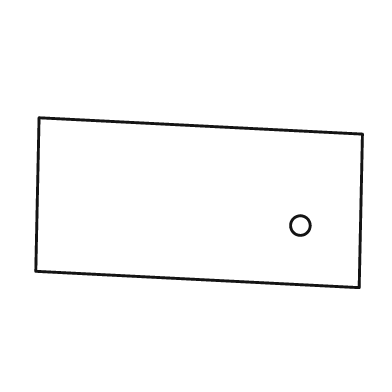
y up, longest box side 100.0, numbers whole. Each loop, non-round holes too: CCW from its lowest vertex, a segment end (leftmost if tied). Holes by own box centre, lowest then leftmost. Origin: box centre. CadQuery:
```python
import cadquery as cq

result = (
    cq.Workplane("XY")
    .moveTo(49.0, -26.0)
    .lineTo(50.0, 21.0)
    .lineTo(-49.0, 26.0)
    .lineTo(-50.0, -21.0)
    .close()
    .moveTo(31.0, -7.0)
    .circle(3.0)
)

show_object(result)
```